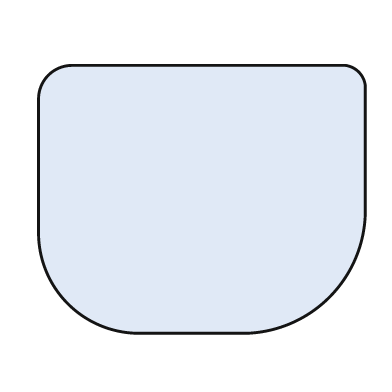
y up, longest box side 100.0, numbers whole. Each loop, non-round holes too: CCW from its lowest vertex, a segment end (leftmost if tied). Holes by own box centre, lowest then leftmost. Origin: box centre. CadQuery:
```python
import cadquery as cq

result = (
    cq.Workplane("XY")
    .moveTo(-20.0, -41.0)
    .lineTo(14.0, -41.0)
    .threePointArc((39.0, -30.0), (50.0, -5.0))
    .lineTo(50.0, 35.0)
    .threePointArc((48.0, 39.0), (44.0, 41.0))
    .lineTo(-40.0, 41.0)
    .threePointArc((-47.0, 38.0), (-50.0, 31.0))
    .lineTo(-50.0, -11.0)
    .threePointArc((-41.0, -32.0), (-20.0, -41.0))
    .close()
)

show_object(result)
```